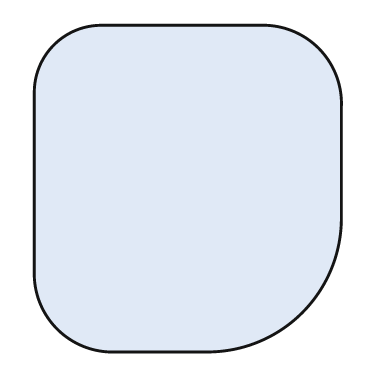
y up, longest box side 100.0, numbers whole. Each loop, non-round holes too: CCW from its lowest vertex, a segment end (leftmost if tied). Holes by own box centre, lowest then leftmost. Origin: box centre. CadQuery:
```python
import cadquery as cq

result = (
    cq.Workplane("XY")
    .moveTo(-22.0, -50.0)
    .lineTo(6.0, -50.0)
    .threePointArc((35.0, -38.0), (47.0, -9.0))
    .lineTo(47.0, 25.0)
    .threePointArc((40.0, 43.0), (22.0, 50.0))
    .lineTo(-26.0, 50.0)
    .threePointArc((-41.0, 44.0), (-47.0, 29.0))
    .lineTo(-47.0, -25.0)
    .threePointArc((-40.0, -43.0), (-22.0, -50.0))
    .close()
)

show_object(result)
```